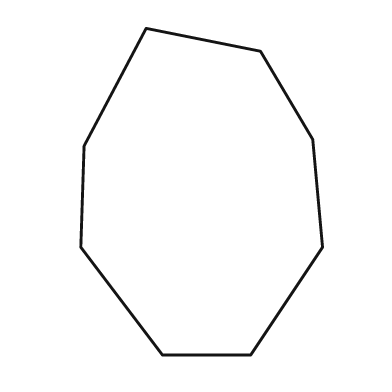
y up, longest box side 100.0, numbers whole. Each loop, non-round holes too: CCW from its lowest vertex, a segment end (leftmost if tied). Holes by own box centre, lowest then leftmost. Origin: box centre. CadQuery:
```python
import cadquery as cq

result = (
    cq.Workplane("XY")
    .moveTo(-12.0, -50.0)
    .lineTo(15.0, -50.0)
    .lineTo(37.0, -17.0)
    .lineTo(34.0, 16.0)
    .lineTo(18.0, 43.0)
    .lineTo(-17.0, 50.0)
    .lineTo(-36.0, 14.0)
    .lineTo(-37.0, -17.0)
    .close()
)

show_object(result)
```